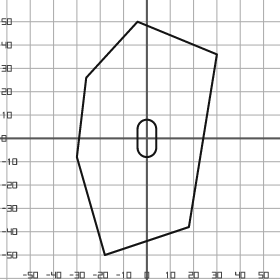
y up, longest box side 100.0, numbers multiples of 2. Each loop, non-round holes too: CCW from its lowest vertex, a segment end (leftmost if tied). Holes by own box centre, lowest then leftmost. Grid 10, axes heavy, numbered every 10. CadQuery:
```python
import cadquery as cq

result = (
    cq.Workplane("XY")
    .moveTo(-18.0, -50.0)
    .lineTo(18.0, -38.0)
    .lineTo(30.0, 36.0)
    .lineTo(-4.0, 50.0)
    .lineTo(-26.0, 26.0)
    .lineTo(-30.0, -8.0)
    .close()
    .moveTo(-4.0, -4.0)
    .threePointArc((0.0, -8.0), (4.0, -4.0))
    .lineTo(4.0, 4.0)
    .threePointArc((0.0, 8.0), (-4.0, 4.0))
    .close()
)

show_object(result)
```